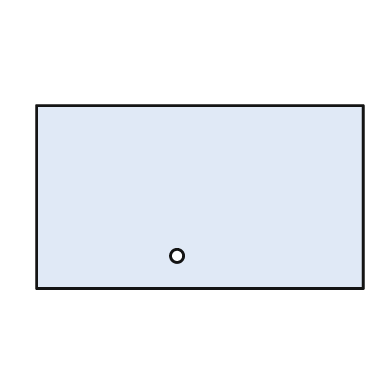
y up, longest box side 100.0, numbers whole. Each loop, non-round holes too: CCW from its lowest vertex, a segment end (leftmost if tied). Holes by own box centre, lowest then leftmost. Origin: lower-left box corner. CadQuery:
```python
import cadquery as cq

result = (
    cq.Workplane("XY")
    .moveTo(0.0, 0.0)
    .lineTo(100.0, 0.0)
    .lineTo(100.0, 56.0)
    .lineTo(0.0, 56.0)
    .close()
    .moveTo(43.0, 10.0)
    .circle(2.0)
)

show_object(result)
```